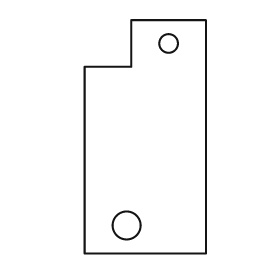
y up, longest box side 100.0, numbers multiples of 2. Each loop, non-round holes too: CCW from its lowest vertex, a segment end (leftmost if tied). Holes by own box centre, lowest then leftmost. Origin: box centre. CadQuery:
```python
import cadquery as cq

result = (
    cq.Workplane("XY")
    .moveTo(-26.0, -50.0)
    .lineTo(26.0, -50.0)
    .lineTo(26.0, 50.0)
    .lineTo(-6.0, 50.0)
    .lineTo(-6.0, 30.0)
    .lineTo(-26.0, 30.0)
    .close()
    .moveTo(-8.0, -38.0)
    .circle(6.0)
    .moveTo(10.0, 40.0)
    .circle(4.0)
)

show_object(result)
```